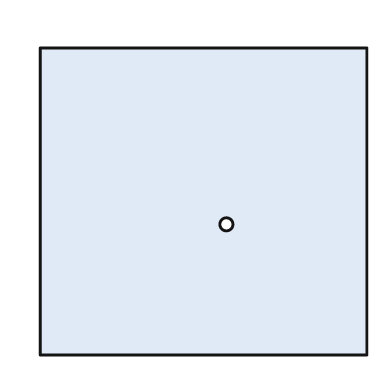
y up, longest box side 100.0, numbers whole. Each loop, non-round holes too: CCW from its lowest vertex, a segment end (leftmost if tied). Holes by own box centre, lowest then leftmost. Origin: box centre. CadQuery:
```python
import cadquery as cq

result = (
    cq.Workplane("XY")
    .moveTo(-50.0, -47.0)
    .lineTo(50.0, -47.0)
    .lineTo(50.0, 47.0)
    .lineTo(-50.0, 47.0)
    .close()
    .moveTo(7.0, -7.0)
    .circle(2.0)
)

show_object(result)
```